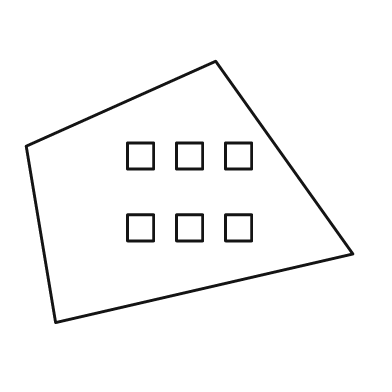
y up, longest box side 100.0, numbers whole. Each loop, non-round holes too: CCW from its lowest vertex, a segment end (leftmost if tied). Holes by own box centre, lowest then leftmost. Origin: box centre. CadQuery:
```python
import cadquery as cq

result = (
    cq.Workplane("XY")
    .moveTo(-41.0, -40.0)
    .lineTo(50.0, -19.0)
    .lineTo(8.0, 40.0)
    .lineTo(-50.0, 14.0)
    .close()
    .moveTo(-19.0, -15.0)
    .lineTo(-11.0, -15.0)
    .lineTo(-11.0, -7.0)
    .lineTo(-19.0, -7.0)
    .close()
    .moveTo(-4.0, -15.0)
    .lineTo(4.0, -15.0)
    .lineTo(4.0, -7.0)
    .lineTo(-4.0, -7.0)
    .close()
    .moveTo(11.0, -15.0)
    .lineTo(19.0, -15.0)
    .lineTo(19.0, -7.0)
    .lineTo(11.0, -7.0)
    .close()
    .moveTo(-19.0, 7.0)
    .lineTo(-11.0, 7.0)
    .lineTo(-11.0, 15.0)
    .lineTo(-19.0, 15.0)
    .close()
    .moveTo(-4.0, 7.0)
    .lineTo(4.0, 7.0)
    .lineTo(4.0, 15.0)
    .lineTo(-4.0, 15.0)
    .close()
    .moveTo(11.0, 7.0)
    .lineTo(19.0, 7.0)
    .lineTo(19.0, 15.0)
    .lineTo(11.0, 15.0)
    .close()
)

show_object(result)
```